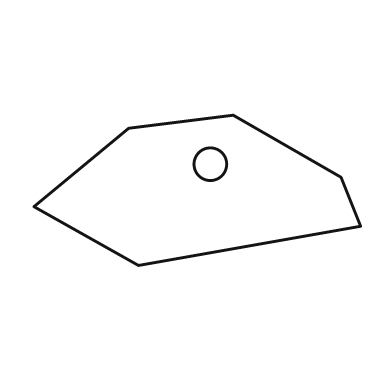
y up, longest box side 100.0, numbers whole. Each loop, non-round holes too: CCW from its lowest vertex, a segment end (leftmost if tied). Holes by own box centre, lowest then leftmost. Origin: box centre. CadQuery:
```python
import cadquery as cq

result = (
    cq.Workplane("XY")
    .moveTo(-18.0, -23.0)
    .lineTo(50.0, -11.0)
    .lineTo(44.0, 4.0)
    .lineTo(11.0, 23.0)
    .lineTo(-21.0, 19.0)
    .lineTo(-50.0, -5.0)
    .close()
    .moveTo(4.0, 8.0)
    .circle(5.0)
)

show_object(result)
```